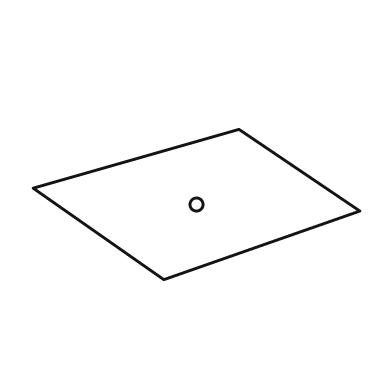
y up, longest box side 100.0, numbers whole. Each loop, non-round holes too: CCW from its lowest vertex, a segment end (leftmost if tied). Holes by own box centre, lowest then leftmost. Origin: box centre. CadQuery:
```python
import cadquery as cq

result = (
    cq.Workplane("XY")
    .moveTo(-10.0, -23.0)
    .lineTo(50.0, -2.0)
    .lineTo(13.0, 23.0)
    .lineTo(-50.0, 5.0)
    .close()
    .moveTo(0.0, 0.0)
    .circle(2.0)
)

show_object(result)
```